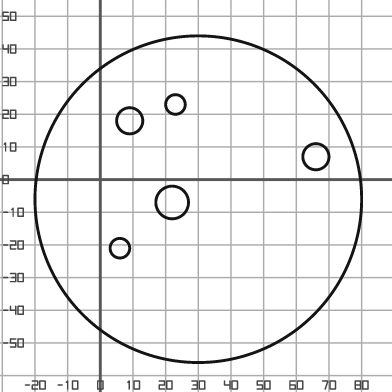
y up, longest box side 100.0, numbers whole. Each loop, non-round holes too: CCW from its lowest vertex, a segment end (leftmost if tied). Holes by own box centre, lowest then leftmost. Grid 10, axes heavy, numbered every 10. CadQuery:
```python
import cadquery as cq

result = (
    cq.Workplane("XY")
    .moveTo(30.0, -6.0)
    .circle(50.0)
    .moveTo(6.0, -21.0)
    .circle(3.0)
    .moveTo(22.0, -7.0)
    .circle(5.0)
    .moveTo(66.0, 7.0)
    .circle(4.0)
    .moveTo(9.0, 18.0)
    .circle(4.0)
    .moveTo(23.0, 23.0)
    .circle(3.0)
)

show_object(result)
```